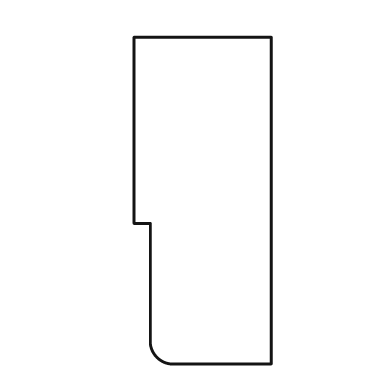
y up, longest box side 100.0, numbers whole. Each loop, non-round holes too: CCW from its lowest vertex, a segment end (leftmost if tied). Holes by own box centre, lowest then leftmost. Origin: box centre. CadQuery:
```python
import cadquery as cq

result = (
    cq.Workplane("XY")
    .moveTo(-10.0, -50.0)
    .lineTo(21.0, -50.0)
    .lineTo(21.0, 50.0)
    .lineTo(-21.0, 50.0)
    .lineTo(-21.0, -7.0)
    .lineTo(-16.0, -7.0)
    .lineTo(-16.0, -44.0)
    .threePointArc((-14.0, -48.0), (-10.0, -50.0))
    .close()
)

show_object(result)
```